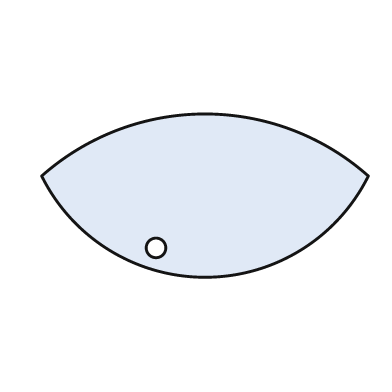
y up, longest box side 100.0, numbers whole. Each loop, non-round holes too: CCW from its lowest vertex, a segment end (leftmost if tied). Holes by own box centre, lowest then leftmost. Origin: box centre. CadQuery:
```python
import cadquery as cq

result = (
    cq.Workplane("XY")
    .moveTo(-50.0, 6.0)
    .threePointArc((0.0, -25.0), (50.0, 6.0))
    .threePointArc((0.0, 25.0), (-50.0, 6.0))
    .close()
    .moveTo(-15.0, -16.0)
    .circle(3.0)
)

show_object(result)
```